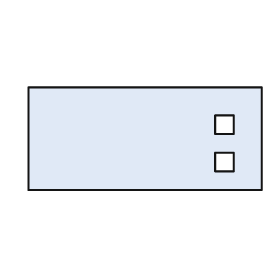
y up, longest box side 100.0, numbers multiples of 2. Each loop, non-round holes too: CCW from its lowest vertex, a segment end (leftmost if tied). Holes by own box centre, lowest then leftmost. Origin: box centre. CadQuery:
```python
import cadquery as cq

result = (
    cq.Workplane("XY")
    .moveTo(-50.0, -22.0)
    .lineTo(50.0, -22.0)
    .lineTo(50.0, 22.0)
    .lineTo(-50.0, 22.0)
    .close()
    .moveTo(30.0, -14.0)
    .lineTo(38.0, -14.0)
    .lineTo(38.0, -6.0)
    .lineTo(30.0, -6.0)
    .close()
    .moveTo(30.0, 2.0)
    .lineTo(38.0, 2.0)
    .lineTo(38.0, 10.0)
    .lineTo(30.0, 10.0)
    .close()
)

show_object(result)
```